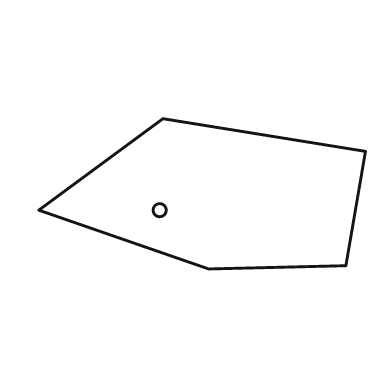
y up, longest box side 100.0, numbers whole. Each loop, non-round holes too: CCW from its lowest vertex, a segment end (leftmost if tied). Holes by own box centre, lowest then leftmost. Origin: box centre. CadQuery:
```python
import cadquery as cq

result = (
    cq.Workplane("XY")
    .moveTo(2.0, -23.0)
    .lineTo(44.0, -22.0)
    .lineTo(50.0, 13.0)
    .lineTo(-12.0, 23.0)
    .lineTo(-50.0, -5.0)
    .close()
    .moveTo(-13.0, -5.0)
    .circle(2.0)
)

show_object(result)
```